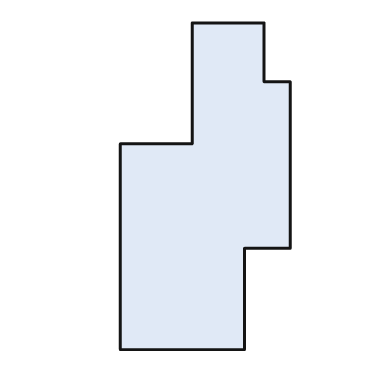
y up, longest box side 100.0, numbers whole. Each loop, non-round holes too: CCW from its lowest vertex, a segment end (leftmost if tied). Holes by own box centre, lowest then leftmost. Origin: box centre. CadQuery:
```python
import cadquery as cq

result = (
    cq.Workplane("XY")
    .moveTo(-26.0, -50.0)
    .lineTo(12.0, -50.0)
    .lineTo(12.0, -19.0)
    .lineTo(26.0, -19.0)
    .lineTo(26.0, 32.0)
    .lineTo(18.0, 32.0)
    .lineTo(18.0, 50.0)
    .lineTo(-4.0, 50.0)
    .lineTo(-4.0, 13.0)
    .lineTo(-26.0, 13.0)
    .close()
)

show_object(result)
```